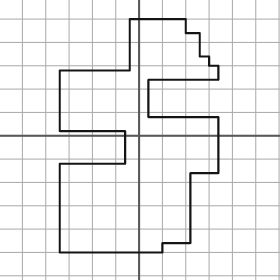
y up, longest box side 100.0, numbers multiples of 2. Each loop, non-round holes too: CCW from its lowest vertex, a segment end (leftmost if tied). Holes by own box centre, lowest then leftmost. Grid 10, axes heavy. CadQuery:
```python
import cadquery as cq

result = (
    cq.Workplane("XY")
    .moveTo(-34.0, -50.0)
    .lineTo(10.0, -50.0)
    .lineTo(10.0, -46.0)
    .lineTo(22.0, -46.0)
    .lineTo(22.0, -16.0)
    .lineTo(34.0, -16.0)
    .lineTo(34.0, 8.0)
    .lineTo(4.0, 8.0)
    .lineTo(4.0, 24.0)
    .lineTo(34.0, 24.0)
    .lineTo(34.0, 30.0)
    .lineTo(30.0, 30.0)
    .lineTo(30.0, 34.0)
    .lineTo(26.0, 34.0)
    .lineTo(26.0, 44.0)
    .lineTo(20.0, 44.0)
    .lineTo(20.0, 50.0)
    .lineTo(-4.0, 50.0)
    .lineTo(-4.0, 28.0)
    .lineTo(-34.0, 28.0)
    .lineTo(-34.0, 2.0)
    .lineTo(-6.0, 2.0)
    .lineTo(-6.0, -12.0)
    .lineTo(-34.0, -12.0)
    .close()
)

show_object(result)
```